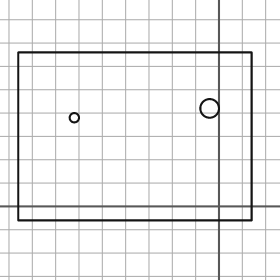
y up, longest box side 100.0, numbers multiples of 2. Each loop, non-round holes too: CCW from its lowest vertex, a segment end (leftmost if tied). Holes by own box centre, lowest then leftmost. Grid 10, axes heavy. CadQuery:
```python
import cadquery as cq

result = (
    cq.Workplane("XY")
    .moveTo(-86.0, -6.0)
    .lineTo(14.0, -6.0)
    .lineTo(14.0, 66.0)
    .lineTo(-86.0, 66.0)
    .close()
    .moveTo(-62.0, 38.0)
    .circle(2.0)
    .moveTo(-4.0, 42.0)
    .circle(4.0)
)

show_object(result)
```